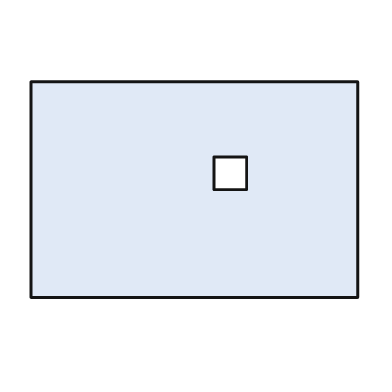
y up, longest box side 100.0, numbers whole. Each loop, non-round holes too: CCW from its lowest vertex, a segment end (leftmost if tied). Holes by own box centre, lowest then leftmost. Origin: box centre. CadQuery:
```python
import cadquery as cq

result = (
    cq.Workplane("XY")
    .moveTo(-50.0, -33.0)
    .lineTo(50.0, -33.0)
    .lineTo(50.0, 33.0)
    .lineTo(-50.0, 33.0)
    .close()
    .moveTo(6.0, 0.0)
    .lineTo(16.0, 0.0)
    .lineTo(16.0, 10.0)
    .lineTo(6.0, 10.0)
    .close()
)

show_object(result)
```